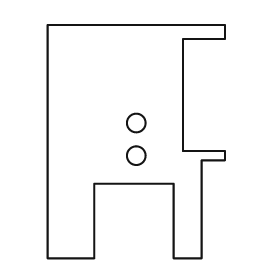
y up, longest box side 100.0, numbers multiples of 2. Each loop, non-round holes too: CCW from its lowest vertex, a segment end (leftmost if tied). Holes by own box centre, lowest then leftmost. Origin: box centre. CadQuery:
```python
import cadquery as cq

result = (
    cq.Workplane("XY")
    .moveTo(-38.0, -50.0)
    .lineTo(-18.0, -50.0)
    .lineTo(-18.0, -18.0)
    .lineTo(16.0, -18.0)
    .lineTo(16.0, -50.0)
    .lineTo(28.0, -50.0)
    .lineTo(28.0, -8.0)
    .lineTo(38.0, -8.0)
    .lineTo(38.0, -4.0)
    .lineTo(20.0, -4.0)
    .lineTo(20.0, 44.0)
    .lineTo(38.0, 44.0)
    .lineTo(38.0, 50.0)
    .lineTo(-38.0, 50.0)
    .close()
    .moveTo(0.0, -6.0)
    .circle(4.0)
    .moveTo(0.0, 8.0)
    .circle(4.0)
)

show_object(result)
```